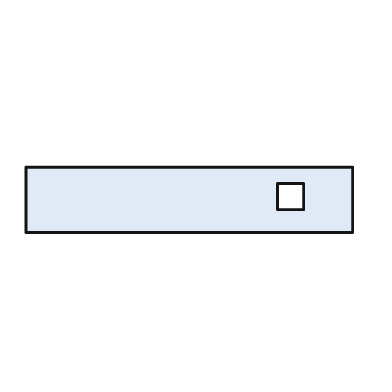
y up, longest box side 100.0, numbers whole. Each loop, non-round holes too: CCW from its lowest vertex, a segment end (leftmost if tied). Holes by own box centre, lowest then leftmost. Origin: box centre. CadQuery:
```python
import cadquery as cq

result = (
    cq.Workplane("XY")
    .moveTo(-50.0, -10.0)
    .lineTo(50.0, -10.0)
    .lineTo(50.0, 10.0)
    .lineTo(-50.0, 10.0)
    .close()
    .moveTo(27.0, -3.0)
    .lineTo(35.0, -3.0)
    .lineTo(35.0, 5.0)
    .lineTo(27.0, 5.0)
    .close()
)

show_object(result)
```